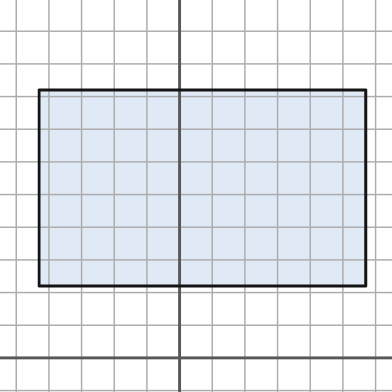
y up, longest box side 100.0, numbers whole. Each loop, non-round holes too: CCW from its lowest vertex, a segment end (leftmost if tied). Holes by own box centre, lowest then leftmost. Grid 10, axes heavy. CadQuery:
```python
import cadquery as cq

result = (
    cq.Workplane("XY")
    .moveTo(-43.0, 22.0)
    .lineTo(57.0, 22.0)
    .lineTo(57.0, 82.0)
    .lineTo(-43.0, 82.0)
    .close()
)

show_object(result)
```